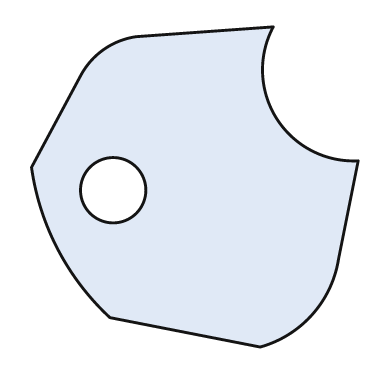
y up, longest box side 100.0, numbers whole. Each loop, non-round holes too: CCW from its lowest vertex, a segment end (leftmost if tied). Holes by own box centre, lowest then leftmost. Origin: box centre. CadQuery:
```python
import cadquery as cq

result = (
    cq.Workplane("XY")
    .moveTo(20.0, -49.0)
    .threePointArc((36.0, -39.0), (44.0, -22.0))
    .lineTo(50.0, 8.0)
    .threePointArc((25.0, 21.0), (24.0, 49.0))
    .lineTo(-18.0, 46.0)
    .threePointArc((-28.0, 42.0), (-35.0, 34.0))
    .lineTo(-50.0, 6.0)
    .threePointArc((-42.0, -19.0), (-26.0, -40.0))
    .close()
    .moveTo(-25.0, -1.0)
    .circle(10.0)
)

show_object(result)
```